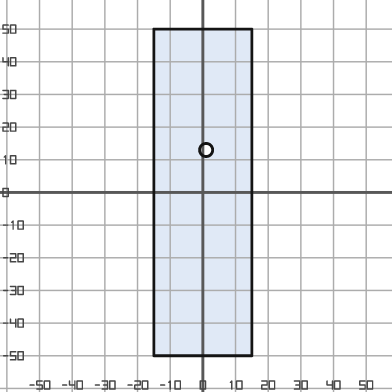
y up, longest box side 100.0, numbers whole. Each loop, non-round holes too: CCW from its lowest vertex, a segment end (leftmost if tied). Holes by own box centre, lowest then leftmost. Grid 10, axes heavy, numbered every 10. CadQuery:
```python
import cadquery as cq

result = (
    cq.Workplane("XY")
    .moveTo(-15.0, -50.0)
    .lineTo(15.0, -50.0)
    .lineTo(15.0, 50.0)
    .lineTo(-15.0, 50.0)
    .close()
    .moveTo(1.0, 13.0)
    .circle(2.0)
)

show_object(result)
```